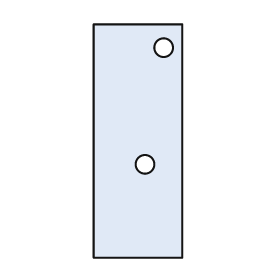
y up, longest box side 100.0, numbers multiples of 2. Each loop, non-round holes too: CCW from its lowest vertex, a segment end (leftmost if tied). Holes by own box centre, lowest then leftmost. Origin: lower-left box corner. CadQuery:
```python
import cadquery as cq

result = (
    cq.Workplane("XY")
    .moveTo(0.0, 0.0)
    .lineTo(38.0, 0.0)
    .lineTo(38.0, 100.0)
    .lineTo(0.0, 100.0)
    .close()
    .moveTo(22.0, 40.0)
    .circle(4.0)
    .moveTo(30.0, 90.0)
    .circle(4.0)
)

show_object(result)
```